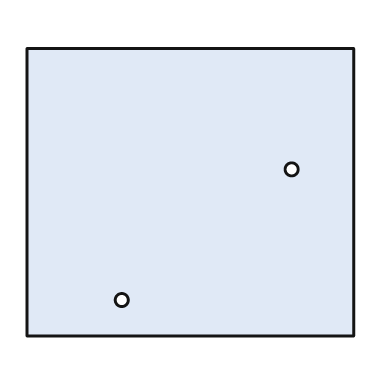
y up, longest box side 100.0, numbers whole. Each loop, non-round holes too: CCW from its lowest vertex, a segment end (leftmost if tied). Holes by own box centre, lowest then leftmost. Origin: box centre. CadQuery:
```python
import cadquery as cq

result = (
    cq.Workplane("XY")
    .moveTo(-50.0, -44.0)
    .lineTo(50.0, -44.0)
    .lineTo(50.0, 44.0)
    .lineTo(-50.0, 44.0)
    .close()
    .moveTo(-21.0, -33.0)
    .circle(2.0)
    .moveTo(31.0, 7.0)
    .circle(2.0)
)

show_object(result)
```